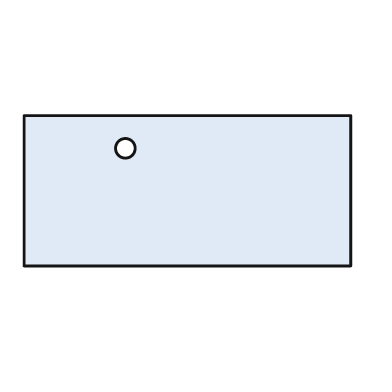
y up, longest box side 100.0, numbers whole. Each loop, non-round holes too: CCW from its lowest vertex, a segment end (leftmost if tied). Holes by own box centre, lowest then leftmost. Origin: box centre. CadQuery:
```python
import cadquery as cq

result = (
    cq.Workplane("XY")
    .moveTo(-50.0, -23.0)
    .lineTo(50.0, -23.0)
    .lineTo(50.0, 23.0)
    .lineTo(-50.0, 23.0)
    .close()
    .moveTo(-19.0, 13.0)
    .circle(3.0)
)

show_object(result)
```